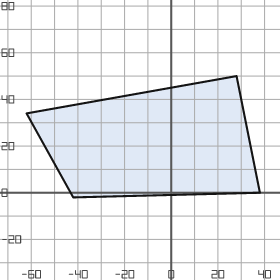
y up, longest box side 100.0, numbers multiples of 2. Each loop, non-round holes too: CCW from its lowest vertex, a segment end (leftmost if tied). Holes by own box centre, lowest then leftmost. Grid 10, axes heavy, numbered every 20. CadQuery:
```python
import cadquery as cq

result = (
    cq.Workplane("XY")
    .moveTo(-42.0, -2.0)
    .lineTo(38.0, 0.0)
    .lineTo(28.0, 50.0)
    .lineTo(-62.0, 34.0)
    .close()
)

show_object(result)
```